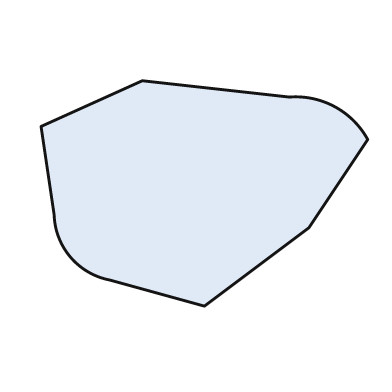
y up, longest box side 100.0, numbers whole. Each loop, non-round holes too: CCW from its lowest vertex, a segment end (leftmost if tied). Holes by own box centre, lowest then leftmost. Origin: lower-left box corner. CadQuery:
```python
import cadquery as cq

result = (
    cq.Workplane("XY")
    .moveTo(50.0, 0.0)
    .lineTo(82.0, 24.0)
    .lineTo(100.0, 51.0)
    .threePointArc((90.0, 61.0), (76.0, 64.0))
    .lineTo(31.0, 69.0)
    .lineTo(0.0, 55.0)
    .lineTo(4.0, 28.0)
    .threePointArc((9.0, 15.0), (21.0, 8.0))
    .close()
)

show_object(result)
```